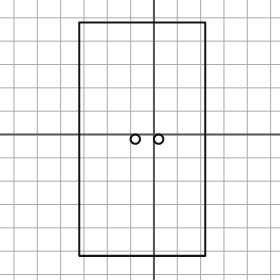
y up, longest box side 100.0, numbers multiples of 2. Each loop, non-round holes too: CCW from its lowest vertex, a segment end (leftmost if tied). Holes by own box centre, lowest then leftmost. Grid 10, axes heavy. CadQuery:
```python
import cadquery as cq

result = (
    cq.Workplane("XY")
    .moveTo(-32.0, -52.0)
    .lineTo(22.0, -52.0)
    .lineTo(22.0, 48.0)
    .lineTo(-32.0, 48.0)
    .close()
    .moveTo(-8.0, -2.0)
    .circle(2.0)
    .moveTo(2.0, -2.0)
    .circle(2.0)
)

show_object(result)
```